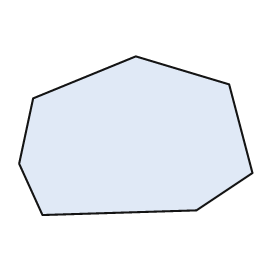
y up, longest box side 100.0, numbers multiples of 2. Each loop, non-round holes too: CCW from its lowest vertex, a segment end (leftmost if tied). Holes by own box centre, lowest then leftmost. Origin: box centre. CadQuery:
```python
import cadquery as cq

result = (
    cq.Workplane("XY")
    .moveTo(-40.0, -34.0)
    .lineTo(26.0, -32.0)
    .lineTo(50.0, -16.0)
    .lineTo(40.0, 22.0)
    .lineTo(0.0, 34.0)
    .lineTo(-44.0, 16.0)
    .lineTo(-50.0, -12.0)
    .close()
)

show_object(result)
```